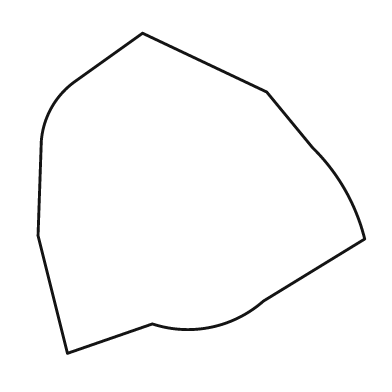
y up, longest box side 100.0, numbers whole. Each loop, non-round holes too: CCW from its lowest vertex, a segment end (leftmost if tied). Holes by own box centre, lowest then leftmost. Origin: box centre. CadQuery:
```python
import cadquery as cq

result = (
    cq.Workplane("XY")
    .moveTo(-41.0, -49.0)
    .lineTo(-15.0, -40.0)
    .threePointArc((3.0, -41.0), (19.0, -33.0))
    .lineTo(50.0, -14.0)
    .threePointArc((44.0, 1.0), (34.0, 14.0))
    .lineTo(20.0, 31.0)
    .lineTo(-18.0, 49.0)
    .lineTo(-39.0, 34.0)
    .threePointArc((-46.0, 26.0), (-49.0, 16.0))
    .lineTo(-50.0, -13.0)
    .close()
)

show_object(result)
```